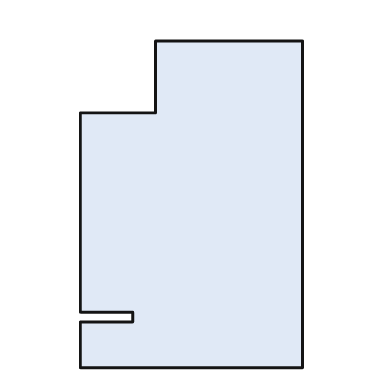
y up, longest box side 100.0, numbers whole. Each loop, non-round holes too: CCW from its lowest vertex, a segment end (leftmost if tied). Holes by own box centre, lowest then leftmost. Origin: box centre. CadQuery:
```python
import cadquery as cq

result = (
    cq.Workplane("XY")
    .moveTo(-34.0, -50.0)
    .lineTo(34.0, -50.0)
    .lineTo(34.0, 50.0)
    .lineTo(-11.0, 50.0)
    .lineTo(-11.0, 28.0)
    .lineTo(-34.0, 28.0)
    .lineTo(-34.0, -33.0)
    .lineTo(-18.0, -33.0)
    .lineTo(-18.0, -36.0)
    .lineTo(-34.0, -36.0)
    .close()
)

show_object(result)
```